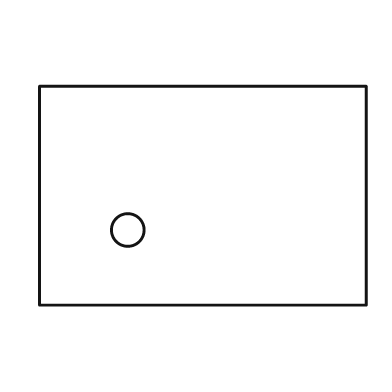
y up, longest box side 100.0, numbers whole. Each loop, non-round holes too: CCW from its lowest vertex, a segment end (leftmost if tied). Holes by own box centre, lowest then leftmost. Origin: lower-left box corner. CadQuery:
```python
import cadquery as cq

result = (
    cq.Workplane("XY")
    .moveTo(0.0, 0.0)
    .lineTo(100.0, 0.0)
    .lineTo(100.0, 67.0)
    .lineTo(0.0, 67.0)
    .close()
    .moveTo(27.0, 23.0)
    .circle(5.0)
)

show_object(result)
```